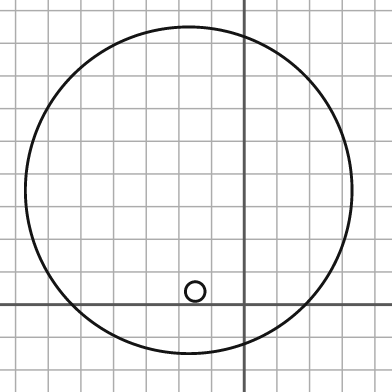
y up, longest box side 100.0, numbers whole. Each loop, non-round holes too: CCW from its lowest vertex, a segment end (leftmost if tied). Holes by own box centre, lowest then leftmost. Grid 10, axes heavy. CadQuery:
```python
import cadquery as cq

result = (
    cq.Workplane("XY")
    .moveTo(-17.0, 35.0)
    .circle(50.0)
    .moveTo(-15.0, 4.0)
    .circle(3.0)
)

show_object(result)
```